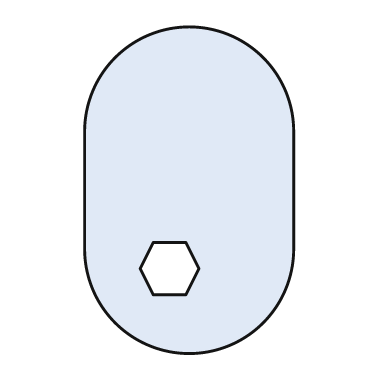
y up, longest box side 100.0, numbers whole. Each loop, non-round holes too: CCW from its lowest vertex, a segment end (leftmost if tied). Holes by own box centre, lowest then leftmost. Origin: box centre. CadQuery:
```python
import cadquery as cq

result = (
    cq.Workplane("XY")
    .moveTo(-32.0, -18.0)
    .threePointArc((0.0, -50.0), (32.0, -18.0))
    .lineTo(32.0, 18.0)
    .threePointArc((0.0, 50.0), (-32.0, 18.0))
    .close()
    .moveTo(-11.0, -32.0)
    .lineTo(-1.0, -32.0)
    .lineTo(3.0, -24.0)
    .lineTo(-1.0, -16.0)
    .lineTo(-11.0, -16.0)
    .lineTo(-15.0, -24.0)
    .close()
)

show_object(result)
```